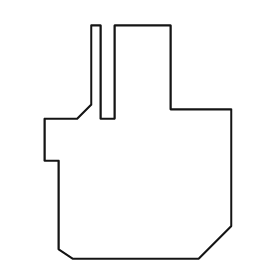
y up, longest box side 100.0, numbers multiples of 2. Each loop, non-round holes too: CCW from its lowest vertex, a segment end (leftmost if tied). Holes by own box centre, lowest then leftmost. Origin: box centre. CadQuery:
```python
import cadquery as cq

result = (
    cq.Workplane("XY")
    .moveTo(-28.0, -50.0)
    .lineTo(26.0, -50.0)
    .lineTo(40.0, -36.0)
    .lineTo(40.0, 14.0)
    .lineTo(14.0, 14.0)
    .lineTo(14.0, 50.0)
    .lineTo(-10.0, 50.0)
    .lineTo(-10.0, 10.0)
    .lineTo(-16.0, 10.0)
    .lineTo(-16.0, 50.0)
    .lineTo(-20.0, 50.0)
    .lineTo(-20.0, 16.0)
    .lineTo(-26.0, 10.0)
    .lineTo(-40.0, 10.0)
    .lineTo(-40.0, -8.0)
    .lineTo(-34.0, -8.0)
    .lineTo(-34.0, -46.0)
    .close()
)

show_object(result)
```